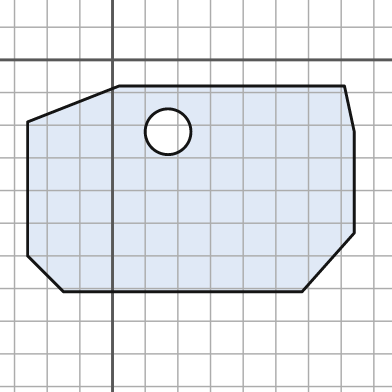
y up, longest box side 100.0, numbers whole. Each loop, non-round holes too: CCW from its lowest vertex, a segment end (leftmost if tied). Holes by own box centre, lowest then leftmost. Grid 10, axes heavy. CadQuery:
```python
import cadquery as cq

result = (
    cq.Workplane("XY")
    .moveTo(-15.0, -71.0)
    .lineTo(58.0, -71.0)
    .lineTo(74.0, -53.0)
    .lineTo(74.0, -22.0)
    .lineTo(71.0, -8.0)
    .lineTo(2.0, -8.0)
    .lineTo(-26.0, -19.0)
    .lineTo(-26.0, -60.0)
    .close()
    .moveTo(17.0, -22.0)
    .circle(7.0)
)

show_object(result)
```